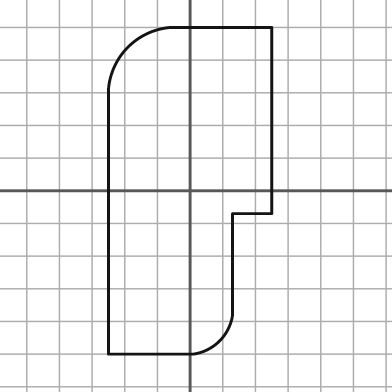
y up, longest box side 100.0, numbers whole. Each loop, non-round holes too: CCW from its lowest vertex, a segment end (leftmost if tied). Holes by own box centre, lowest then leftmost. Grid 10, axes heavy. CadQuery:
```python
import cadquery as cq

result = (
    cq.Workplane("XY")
    .moveTo(-25.0, -50.0)
    .lineTo(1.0, -50.0)
    .threePointArc((9.0, -46.0), (13.0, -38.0))
    .lineTo(13.0, -7.0)
    .lineTo(25.0, -7.0)
    .lineTo(25.0, 50.0)
    .lineTo(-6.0, 50.0)
    .threePointArc((-19.0, 44.0), (-25.0, 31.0))
    .close()
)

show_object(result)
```